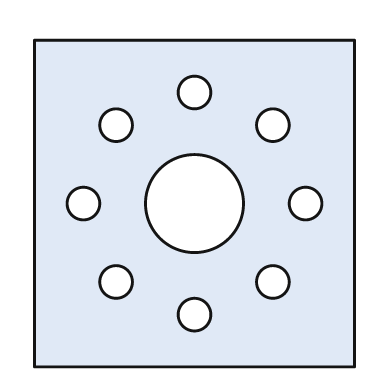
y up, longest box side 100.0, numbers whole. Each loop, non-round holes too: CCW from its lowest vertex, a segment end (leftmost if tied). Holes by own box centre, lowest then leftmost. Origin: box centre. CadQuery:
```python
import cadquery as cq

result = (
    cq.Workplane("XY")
    .moveTo(-49.0, -50.0)
    .lineTo(49.0, -50.0)
    .lineTo(49.0, 50.0)
    .lineTo(-49.0, 50.0)
    .close()
    .moveTo(0.0, -34.0)
    .circle(5.0)
    .moveTo(-24.0, -24.0)
    .circle(5.0)
    .moveTo(24.0, -24.0)
    .circle(5.0)
    .moveTo(-34.0, 0.0)
    .circle(5.0)
    .moveTo(0.0, 0.0)
    .circle(15.0)
    .moveTo(34.0, 0.0)
    .circle(5.0)
    .moveTo(-24.0, 24.0)
    .circle(5.0)
    .moveTo(24.0, 24.0)
    .circle(5.0)
    .moveTo(0.0, 34.0)
    .circle(5.0)
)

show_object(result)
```